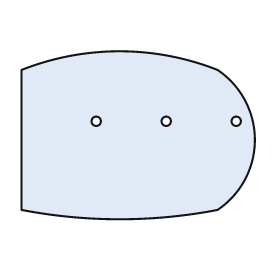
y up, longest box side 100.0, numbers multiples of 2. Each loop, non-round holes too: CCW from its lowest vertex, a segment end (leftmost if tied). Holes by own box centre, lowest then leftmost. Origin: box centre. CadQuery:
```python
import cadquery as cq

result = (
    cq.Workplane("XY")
    .moveTo(-50.0, -32.0)
    .threePointArc((-8.0, -36.0), (34.0, -32.0))
    .threePointArc((50.0, -2.0), (34.0, 28.0))
    .threePointArc((-8.0, 36.0), (-50.0, 28.0))
    .close()
    .moveTo(-18.0, 6.0)
    .circle(2.0)
    .moveTo(12.0, 6.0)
    .circle(2.0)
    .moveTo(42.0, 6.0)
    .circle(2.0)
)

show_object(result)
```